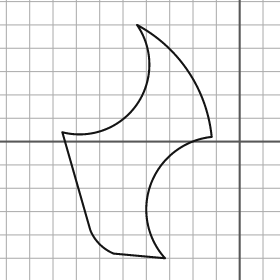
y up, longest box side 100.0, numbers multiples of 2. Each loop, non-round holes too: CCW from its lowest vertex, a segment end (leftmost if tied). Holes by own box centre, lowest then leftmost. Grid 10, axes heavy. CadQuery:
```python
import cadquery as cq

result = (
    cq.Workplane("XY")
    .moveTo(-32.0, -50.0)
    .threePointArc((-38.0, -18.0), (-12.0, 2.0))
    .threePointArc((-22.0, 30.0), (-44.0, 50.0))
    .threePointArc((-44.0, 16.0), (-76.0, 4.0))
    .lineTo(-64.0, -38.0)
    .threePointArc((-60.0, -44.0), (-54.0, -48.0))
    .close()
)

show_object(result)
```